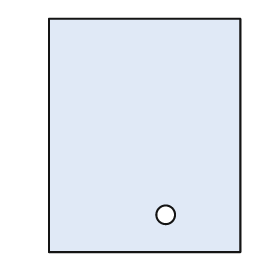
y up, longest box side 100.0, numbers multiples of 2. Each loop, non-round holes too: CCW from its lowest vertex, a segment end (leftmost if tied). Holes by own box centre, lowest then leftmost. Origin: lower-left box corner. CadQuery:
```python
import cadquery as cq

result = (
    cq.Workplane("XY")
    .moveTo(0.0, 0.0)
    .lineTo(82.0, 0.0)
    .lineTo(82.0, 100.0)
    .lineTo(0.0, 100.0)
    .close()
    .moveTo(50.0, 16.0)
    .circle(4.0)
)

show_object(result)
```